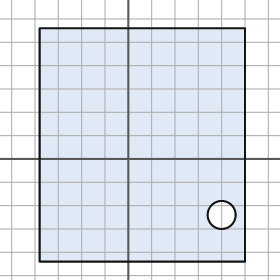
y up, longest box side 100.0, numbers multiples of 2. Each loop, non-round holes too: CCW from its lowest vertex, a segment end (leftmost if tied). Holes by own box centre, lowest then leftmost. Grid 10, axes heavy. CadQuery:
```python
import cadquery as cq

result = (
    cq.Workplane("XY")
    .moveTo(-38.0, -44.0)
    .lineTo(50.0, -44.0)
    .lineTo(50.0, 56.0)
    .lineTo(-38.0, 56.0)
    .close()
    .moveTo(40.0, -24.0)
    .circle(6.0)
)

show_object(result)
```